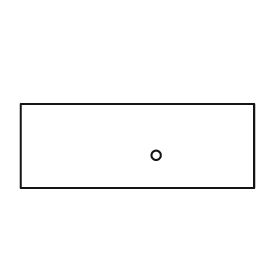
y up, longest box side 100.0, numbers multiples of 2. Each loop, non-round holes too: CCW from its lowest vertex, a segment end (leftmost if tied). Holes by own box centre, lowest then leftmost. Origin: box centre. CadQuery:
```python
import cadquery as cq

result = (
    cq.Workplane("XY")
    .moveTo(-50.0, -18.0)
    .lineTo(50.0, -18.0)
    .lineTo(50.0, 18.0)
    .lineTo(-50.0, 18.0)
    .close()
    .moveTo(8.0, -4.0)
    .circle(2.0)
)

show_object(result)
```